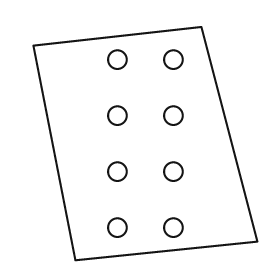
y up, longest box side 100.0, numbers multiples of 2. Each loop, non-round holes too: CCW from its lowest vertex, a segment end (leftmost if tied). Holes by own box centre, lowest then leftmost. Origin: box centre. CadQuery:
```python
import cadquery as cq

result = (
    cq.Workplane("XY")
    .moveTo(-30.0, -50.0)
    .lineTo(48.0, -42.0)
    .lineTo(24.0, 50.0)
    .lineTo(-48.0, 42.0)
    .close()
    .moveTo(-12.0, -36.0)
    .circle(4.0)
    .moveTo(12.0, -36.0)
    .circle(4.0)
    .moveTo(-12.0, -12.0)
    .circle(4.0)
    .moveTo(12.0, -12.0)
    .circle(4.0)
    .moveTo(-12.0, 12.0)
    .circle(4.0)
    .moveTo(12.0, 12.0)
    .circle(4.0)
    .moveTo(-12.0, 36.0)
    .circle(4.0)
    .moveTo(12.0, 36.0)
    .circle(4.0)
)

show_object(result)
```